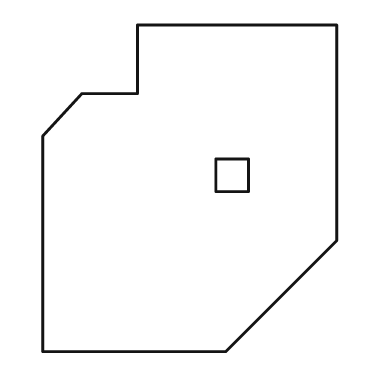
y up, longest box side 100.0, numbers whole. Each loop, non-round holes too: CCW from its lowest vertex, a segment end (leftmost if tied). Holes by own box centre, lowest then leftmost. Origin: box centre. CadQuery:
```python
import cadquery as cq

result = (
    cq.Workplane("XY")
    .moveTo(-45.0, -50.0)
    .lineTo(11.0, -50.0)
    .lineTo(45.0, -16.0)
    .lineTo(45.0, 50.0)
    .lineTo(-16.0, 50.0)
    .lineTo(-16.0, 29.0)
    .lineTo(-33.0, 29.0)
    .lineTo(-45.0, 16.0)
    .close()
    .moveTo(8.0, -1.0)
    .lineTo(18.0, -1.0)
    .lineTo(18.0, 9.0)
    .lineTo(8.0, 9.0)
    .close()
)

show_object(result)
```